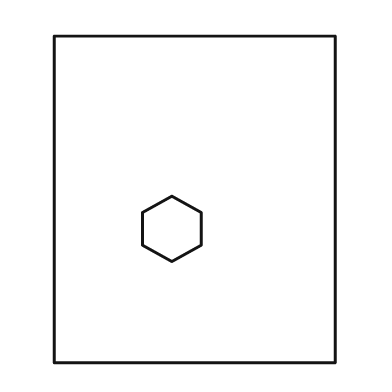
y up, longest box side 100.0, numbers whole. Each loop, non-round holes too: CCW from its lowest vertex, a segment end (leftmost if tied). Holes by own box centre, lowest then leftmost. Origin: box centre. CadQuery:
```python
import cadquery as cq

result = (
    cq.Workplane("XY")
    .moveTo(-43.0, -50.0)
    .lineTo(43.0, -50.0)
    .lineTo(43.0, 50.0)
    .lineTo(-43.0, 50.0)
    .close()
    .moveTo(-7.0, -19.0)
    .lineTo(2.0, -14.0)
    .lineTo(2.0, -4.0)
    .lineTo(-7.0, 1.0)
    .lineTo(-16.0, -4.0)
    .lineTo(-16.0, -14.0)
    .close()
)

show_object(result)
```